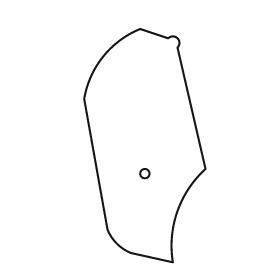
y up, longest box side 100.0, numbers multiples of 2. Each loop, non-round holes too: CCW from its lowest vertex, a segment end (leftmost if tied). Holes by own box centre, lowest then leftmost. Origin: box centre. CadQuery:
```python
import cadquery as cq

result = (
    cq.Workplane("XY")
    .moveTo(12.0, -50.0)
    .threePointArc((14.0, -28.0), (26.0, -10.0))
    .lineTo(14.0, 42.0)
    .threePointArc((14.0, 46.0), (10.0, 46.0))
    .lineTo(-2.0, 50.0)
    .threePointArc((-18.0, 38.0), (-26.0, 20.0))
    .lineTo(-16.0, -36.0)
    .threePointArc((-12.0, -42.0), (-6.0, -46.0))
    .close()
    .moveTo(0.0, -12.0)
    .circle(2.0)
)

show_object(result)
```